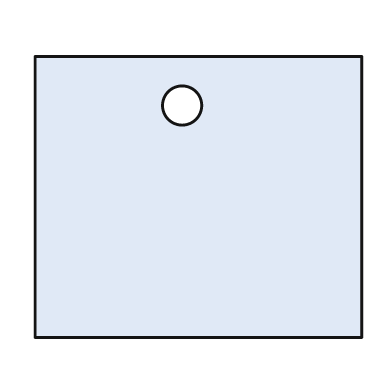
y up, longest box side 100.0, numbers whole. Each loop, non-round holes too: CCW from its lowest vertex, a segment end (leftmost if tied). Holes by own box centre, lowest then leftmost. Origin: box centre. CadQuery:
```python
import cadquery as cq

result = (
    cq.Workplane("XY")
    .moveTo(-50.0, -43.0)
    .lineTo(50.0, -43.0)
    .lineTo(50.0, 43.0)
    .lineTo(-50.0, 43.0)
    .close()
    .moveTo(-5.0, 28.0)
    .circle(6.0)
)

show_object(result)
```